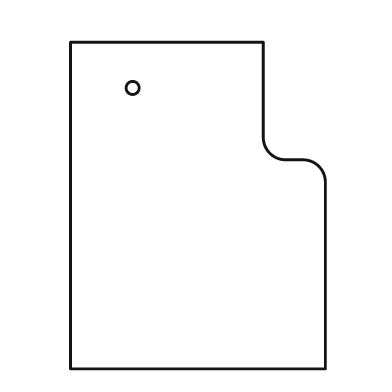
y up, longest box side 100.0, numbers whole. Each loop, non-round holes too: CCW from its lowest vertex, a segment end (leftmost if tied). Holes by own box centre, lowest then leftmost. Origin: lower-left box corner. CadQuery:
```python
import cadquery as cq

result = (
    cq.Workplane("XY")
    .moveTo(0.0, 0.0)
    .lineTo(78.0, 0.0)
    .lineTo(78.0, 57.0)
    .threePointArc((76.0, 62.0), (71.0, 64.0))
    .lineTo(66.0, 64.0)
    .threePointArc((61.0, 66.0), (59.0, 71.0))
    .lineTo(59.0, 100.0)
    .lineTo(0.0, 100.0)
    .close()
    .moveTo(19.0, 86.0)
    .circle(2.0)
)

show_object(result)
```